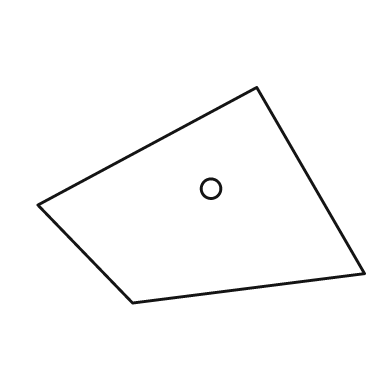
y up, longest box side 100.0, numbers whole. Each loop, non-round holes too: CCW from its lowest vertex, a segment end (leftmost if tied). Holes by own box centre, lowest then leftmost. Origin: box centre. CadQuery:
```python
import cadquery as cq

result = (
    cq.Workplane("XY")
    .moveTo(-21.0, -33.0)
    .lineTo(50.0, -24.0)
    .lineTo(17.0, 33.0)
    .lineTo(-50.0, -3.0)
    .close()
    .moveTo(3.0, 2.0)
    .circle(3.0)
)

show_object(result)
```